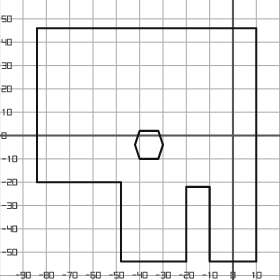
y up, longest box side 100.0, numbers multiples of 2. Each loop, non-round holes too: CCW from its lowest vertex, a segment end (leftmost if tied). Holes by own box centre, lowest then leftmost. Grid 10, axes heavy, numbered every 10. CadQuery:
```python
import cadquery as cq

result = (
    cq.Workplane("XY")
    .moveTo(-48.0, -54.0)
    .lineTo(-20.0, -54.0)
    .lineTo(-20.0, -22.0)
    .lineTo(-10.0, -22.0)
    .lineTo(-10.0, -54.0)
    .lineTo(10.0, -54.0)
    .lineTo(10.0, 46.0)
    .lineTo(-84.0, 46.0)
    .lineTo(-84.0, -20.0)
    .lineTo(-48.0, -20.0)
    .close()
    .moveTo(-40.0, -10.0)
    .lineTo(-32.0, -10.0)
    .lineTo(-30.0, -4.0)
    .lineTo(-32.0, 2.0)
    .lineTo(-40.0, 2.0)
    .lineTo(-42.0, -4.0)
    .close()
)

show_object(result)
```